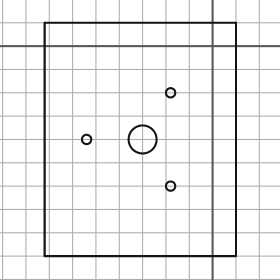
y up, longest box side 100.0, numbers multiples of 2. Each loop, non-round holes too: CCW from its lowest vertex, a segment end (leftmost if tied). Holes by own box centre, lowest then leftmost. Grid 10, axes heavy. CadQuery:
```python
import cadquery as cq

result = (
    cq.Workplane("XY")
    .moveTo(-72.0, -90.0)
    .lineTo(10.0, -90.0)
    .lineTo(10.0, 10.0)
    .lineTo(-72.0, 10.0)
    .close()
    .moveTo(-18.0, -60.0)
    .circle(2.0)
    .moveTo(-54.0, -40.0)
    .circle(2.0)
    .moveTo(-30.0, -40.0)
    .circle(6.0)
    .moveTo(-18.0, -20.0)
    .circle(2.0)
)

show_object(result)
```